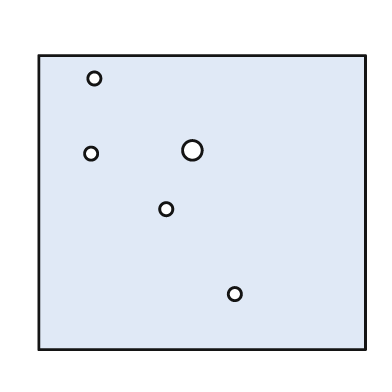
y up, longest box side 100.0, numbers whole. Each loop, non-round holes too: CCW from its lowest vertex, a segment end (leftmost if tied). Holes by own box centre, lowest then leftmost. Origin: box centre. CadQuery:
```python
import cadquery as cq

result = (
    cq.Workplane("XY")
    .moveTo(-50.0, -45.0)
    .lineTo(50.0, -45.0)
    .lineTo(50.0, 45.0)
    .lineTo(-50.0, 45.0)
    .close()
    .moveTo(10.0, -28.0)
    .circle(2.0)
    .moveTo(-11.0, -2.0)
    .circle(2.0)
    .moveTo(-34.0, 15.0)
    .circle(2.0)
    .moveTo(-3.0, 16.0)
    .circle(3.0)
    .moveTo(-33.0, 38.0)
    .circle(2.0)
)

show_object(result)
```